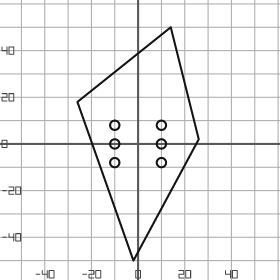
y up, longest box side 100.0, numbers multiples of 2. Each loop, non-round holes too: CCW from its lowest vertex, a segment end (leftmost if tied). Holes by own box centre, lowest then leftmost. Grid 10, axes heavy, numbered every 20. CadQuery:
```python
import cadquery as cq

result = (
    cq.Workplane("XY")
    .moveTo(-2.0, -50.0)
    .lineTo(26.0, 2.0)
    .lineTo(14.0, 50.0)
    .lineTo(-26.0, 18.0)
    .close()
    .moveTo(-10.0, -8.0)
    .circle(2.0)
    .moveTo(10.0, -8.0)
    .circle(2.0)
    .moveTo(-10.0, 0.0)
    .circle(2.0)
    .moveTo(10.0, 0.0)
    .circle(2.0)
    .moveTo(-10.0, 8.0)
    .circle(2.0)
    .moveTo(10.0, 8.0)
    .circle(2.0)
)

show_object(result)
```